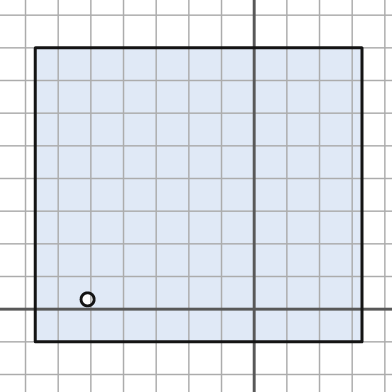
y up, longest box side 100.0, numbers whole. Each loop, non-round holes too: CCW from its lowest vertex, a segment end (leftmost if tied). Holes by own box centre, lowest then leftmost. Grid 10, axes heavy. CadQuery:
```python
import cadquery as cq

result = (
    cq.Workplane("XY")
    .moveTo(-67.0, -10.0)
    .lineTo(33.0, -10.0)
    .lineTo(33.0, 80.0)
    .lineTo(-67.0, 80.0)
    .close()
    .moveTo(-51.0, 3.0)
    .circle(2.0)
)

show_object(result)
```